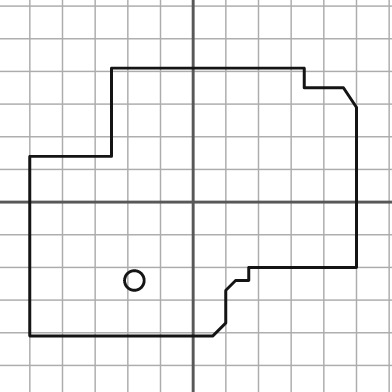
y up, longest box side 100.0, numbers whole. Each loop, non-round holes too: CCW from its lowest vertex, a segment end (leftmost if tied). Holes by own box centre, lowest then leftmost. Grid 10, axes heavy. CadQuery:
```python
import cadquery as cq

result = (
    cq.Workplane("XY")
    .moveTo(-50.0, -41.0)
    .lineTo(6.0, -41.0)
    .lineTo(10.0, -37.0)
    .lineTo(10.0, -27.0)
    .lineTo(13.0, -24.0)
    .lineTo(17.0, -24.0)
    .lineTo(17.0, -20.0)
    .lineTo(50.0, -20.0)
    .lineTo(50.0, 29.0)
    .lineTo(46.0, 35.0)
    .lineTo(34.0, 35.0)
    .lineTo(34.0, 41.0)
    .lineTo(-25.0, 41.0)
    .lineTo(-25.0, 14.0)
    .lineTo(-50.0, 14.0)
    .close()
    .moveTo(-18.0, -24.0)
    .circle(3.0)
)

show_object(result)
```